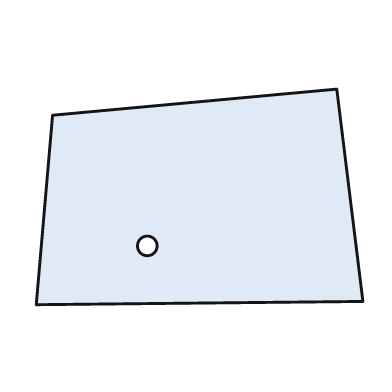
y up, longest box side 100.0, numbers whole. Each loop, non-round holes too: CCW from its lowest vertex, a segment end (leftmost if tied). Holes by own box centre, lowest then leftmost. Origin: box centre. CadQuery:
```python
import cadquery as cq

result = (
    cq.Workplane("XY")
    .moveTo(-50.0, -33.0)
    .lineTo(50.0, -32.0)
    .lineTo(42.0, 33.0)
    .lineTo(-45.0, 25.0)
    .close()
    .moveTo(-16.0, -15.0)
    .circle(3.0)
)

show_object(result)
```